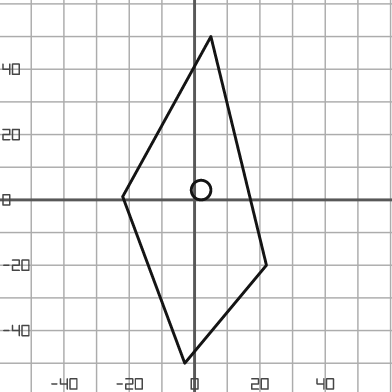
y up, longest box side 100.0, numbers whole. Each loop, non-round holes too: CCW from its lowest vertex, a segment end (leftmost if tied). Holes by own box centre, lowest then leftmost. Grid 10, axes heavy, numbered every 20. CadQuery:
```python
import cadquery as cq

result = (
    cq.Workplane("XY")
    .moveTo(-3.0, -50.0)
    .lineTo(22.0, -20.0)
    .lineTo(5.0, 50.0)
    .lineTo(-22.0, 1.0)
    .close()
    .moveTo(2.0, 3.0)
    .circle(3.0)
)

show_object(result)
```